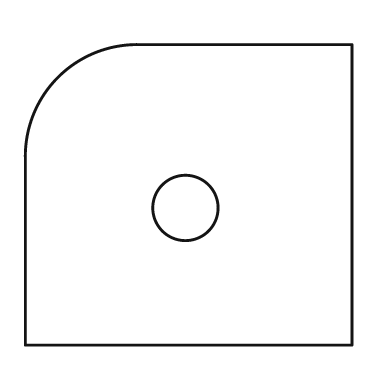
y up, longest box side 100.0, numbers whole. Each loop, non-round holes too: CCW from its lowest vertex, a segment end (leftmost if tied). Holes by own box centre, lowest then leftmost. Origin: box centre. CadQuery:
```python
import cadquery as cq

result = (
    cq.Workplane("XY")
    .moveTo(-50.0, -46.0)
    .lineTo(50.0, -46.0)
    .lineTo(50.0, 46.0)
    .lineTo(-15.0, 46.0)
    .threePointArc((-40.0, 36.0), (-50.0, 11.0))
    .close()
    .moveTo(-1.0, -4.0)
    .circle(10.0)
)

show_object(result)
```